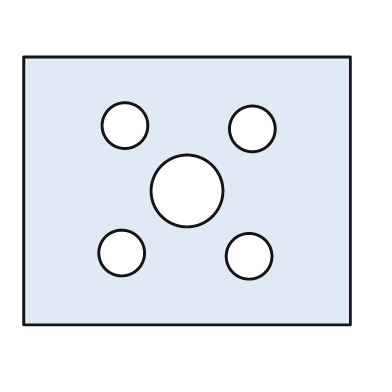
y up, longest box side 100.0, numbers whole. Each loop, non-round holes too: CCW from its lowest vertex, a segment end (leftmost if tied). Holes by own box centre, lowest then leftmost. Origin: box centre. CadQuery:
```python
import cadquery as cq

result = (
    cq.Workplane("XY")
    .moveTo(-50.0, -41.0)
    .lineTo(50.0, -41.0)
    .lineTo(50.0, 41.0)
    .lineTo(-50.0, 41.0)
    .close()
    .moveTo(19.0, -20.0)
    .circle(7.0)
    .moveTo(-20.0, -19.0)
    .circle(7.0)
    .moveTo(0.0, 0.0)
    .circle(11.0)
    .moveTo(20.0, 19.0)
    .circle(7.0)
    .moveTo(-19.0, 20.0)
    .circle(7.0)
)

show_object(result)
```